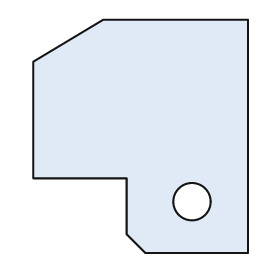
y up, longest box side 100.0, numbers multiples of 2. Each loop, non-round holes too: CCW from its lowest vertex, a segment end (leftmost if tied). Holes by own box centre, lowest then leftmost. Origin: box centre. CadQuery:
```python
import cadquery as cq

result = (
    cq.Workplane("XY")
    .moveTo(2.0, -50.0)
    .lineTo(46.0, -50.0)
    .lineTo(46.0, 50.0)
    .lineTo(-16.0, 50.0)
    .lineTo(-46.0, 32.0)
    .lineTo(-46.0, -18.0)
    .lineTo(-6.0, -18.0)
    .lineTo(-6.0, -42.0)
    .close()
    .moveTo(22.0, -28.0)
    .circle(8.0)
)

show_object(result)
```